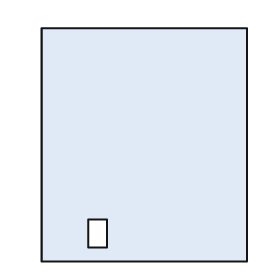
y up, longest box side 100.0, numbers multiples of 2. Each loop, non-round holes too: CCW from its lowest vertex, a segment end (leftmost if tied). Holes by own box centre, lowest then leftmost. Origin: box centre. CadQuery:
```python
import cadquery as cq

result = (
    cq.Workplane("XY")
    .moveTo(-44.0, -50.0)
    .lineTo(44.0, -50.0)
    .lineTo(44.0, 50.0)
    .lineTo(-44.0, 50.0)
    .close()
    .moveTo(-24.0, -44.0)
    .lineTo(-16.0, -44.0)
    .lineTo(-16.0, -32.0)
    .lineTo(-24.0, -32.0)
    .close()
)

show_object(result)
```